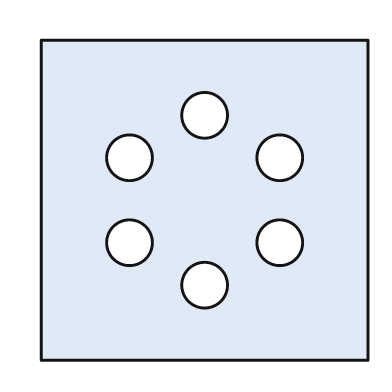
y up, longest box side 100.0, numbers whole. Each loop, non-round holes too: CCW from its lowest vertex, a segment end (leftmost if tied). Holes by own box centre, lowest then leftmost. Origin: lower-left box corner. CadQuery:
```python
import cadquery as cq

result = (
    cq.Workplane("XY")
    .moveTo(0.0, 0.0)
    .lineTo(100.0, 0.0)
    .lineTo(100.0, 98.0)
    .lineTo(0.0, 98.0)
    .close()
    .moveTo(50.0, 23.0)
    .circle(7.0)
    .moveTo(27.0, 36.0)
    .circle(7.0)
    .moveTo(73.0, 36.0)
    .circle(7.0)
    .moveTo(27.0, 62.0)
    .circle(7.0)
    .moveTo(73.0, 62.0)
    .circle(7.0)
    .moveTo(50.0, 75.0)
    .circle(7.0)
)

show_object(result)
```